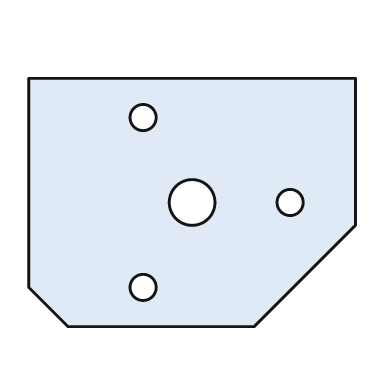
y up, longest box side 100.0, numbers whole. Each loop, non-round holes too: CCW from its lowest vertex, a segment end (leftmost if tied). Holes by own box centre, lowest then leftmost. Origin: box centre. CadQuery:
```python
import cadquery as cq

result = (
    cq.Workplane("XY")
    .moveTo(-38.0, -38.0)
    .lineTo(19.0, -38.0)
    .lineTo(50.0, -7.0)
    .lineTo(50.0, 38.0)
    .lineTo(-50.0, 38.0)
    .lineTo(-50.0, -26.0)
    .close()
    .moveTo(-15.0, -26.0)
    .circle(4.0)
    .moveTo(0.0, 0.0)
    .circle(7.0)
    .moveTo(30.0, 0.0)
    .circle(4.0)
    .moveTo(-15.0, 26.0)
    .circle(4.0)
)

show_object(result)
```